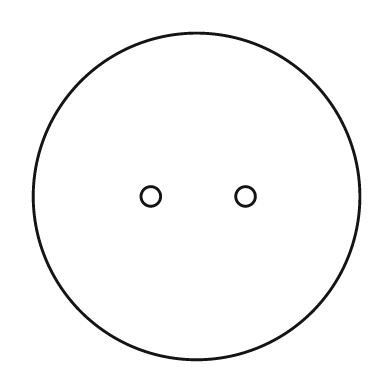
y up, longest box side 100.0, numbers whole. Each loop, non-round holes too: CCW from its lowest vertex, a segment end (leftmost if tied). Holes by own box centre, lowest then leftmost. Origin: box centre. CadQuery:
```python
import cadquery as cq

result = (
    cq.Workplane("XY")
    .moveTo(0.0, 0.0)
    .circle(50.0)
    .moveTo(-14.0, 0.0)
    .circle(3.0)
    .moveTo(15.0, 0.0)
    .circle(3.0)
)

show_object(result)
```